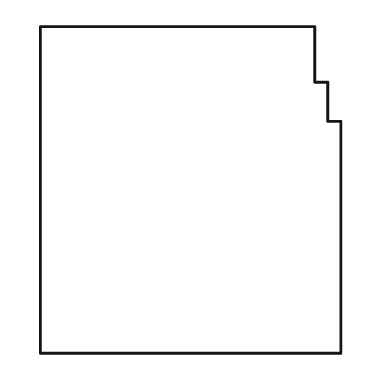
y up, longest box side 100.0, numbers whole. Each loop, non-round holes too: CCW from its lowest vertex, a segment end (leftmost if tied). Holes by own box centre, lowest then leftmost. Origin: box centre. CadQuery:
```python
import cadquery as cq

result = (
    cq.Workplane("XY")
    .moveTo(-46.0, -50.0)
    .lineTo(46.0, -50.0)
    .lineTo(46.0, 21.0)
    .lineTo(42.0, 21.0)
    .lineTo(42.0, 33.0)
    .lineTo(38.0, 33.0)
    .lineTo(38.0, 50.0)
    .lineTo(-46.0, 50.0)
    .close()
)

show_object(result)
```